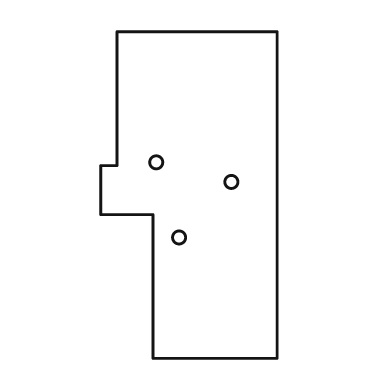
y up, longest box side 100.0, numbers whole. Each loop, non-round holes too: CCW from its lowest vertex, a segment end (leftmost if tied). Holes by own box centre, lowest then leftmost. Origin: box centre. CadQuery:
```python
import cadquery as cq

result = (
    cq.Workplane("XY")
    .moveTo(-11.0, -50.0)
    .lineTo(27.0, -50.0)
    .lineTo(27.0, 50.0)
    .lineTo(-22.0, 50.0)
    .lineTo(-22.0, 9.0)
    .lineTo(-27.0, 9.0)
    .lineTo(-27.0, -6.0)
    .lineTo(-11.0, -6.0)
    .close()
    .moveTo(-3.0, -13.0)
    .circle(2.0)
    .moveTo(13.0, 4.0)
    .circle(2.0)
    .moveTo(-10.0, 10.0)
    .circle(2.0)
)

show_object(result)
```